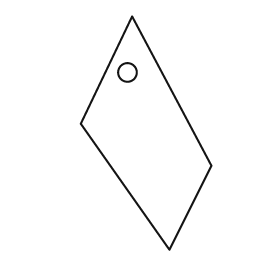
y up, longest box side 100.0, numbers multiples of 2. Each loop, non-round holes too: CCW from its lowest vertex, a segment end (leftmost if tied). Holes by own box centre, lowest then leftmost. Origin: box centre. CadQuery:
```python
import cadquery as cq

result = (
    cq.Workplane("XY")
    .moveTo(10.0, -50.0)
    .lineTo(28.0, -14.0)
    .lineTo(-6.0, 50.0)
    .lineTo(-28.0, 4.0)
    .close()
    .moveTo(-8.0, 26.0)
    .circle(4.0)
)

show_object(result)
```